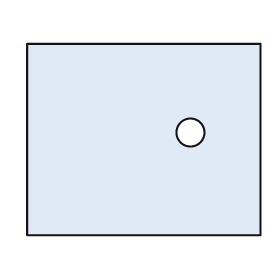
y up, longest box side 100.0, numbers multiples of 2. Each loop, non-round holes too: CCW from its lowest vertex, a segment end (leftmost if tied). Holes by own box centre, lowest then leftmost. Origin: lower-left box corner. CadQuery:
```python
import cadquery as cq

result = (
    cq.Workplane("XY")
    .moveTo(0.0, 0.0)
    .lineTo(100.0, 0.0)
    .lineTo(100.0, 82.0)
    .lineTo(0.0, 82.0)
    .close()
    .moveTo(70.0, 44.0)
    .circle(6.0)
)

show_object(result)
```